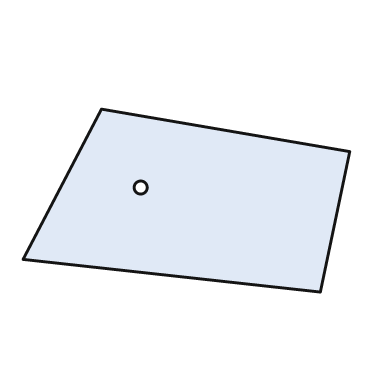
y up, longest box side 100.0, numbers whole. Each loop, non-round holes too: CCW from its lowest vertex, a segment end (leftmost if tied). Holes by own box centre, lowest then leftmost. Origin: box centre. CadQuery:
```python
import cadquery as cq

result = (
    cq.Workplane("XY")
    .moveTo(41.0, -28.0)
    .lineTo(50.0, 15.0)
    .lineTo(-26.0, 28.0)
    .lineTo(-50.0, -18.0)
    .close()
    .moveTo(-14.0, 4.0)
    .circle(2.0)
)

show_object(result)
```